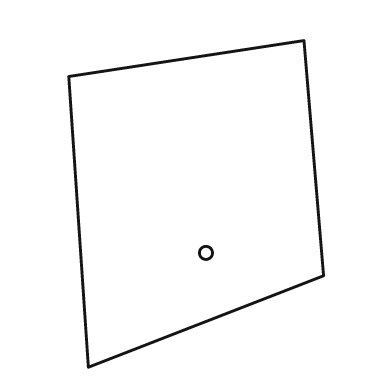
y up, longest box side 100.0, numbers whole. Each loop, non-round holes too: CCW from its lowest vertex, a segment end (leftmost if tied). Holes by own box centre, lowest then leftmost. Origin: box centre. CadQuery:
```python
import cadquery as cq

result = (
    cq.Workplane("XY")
    .moveTo(-33.0, -50.0)
    .lineTo(39.0, -22.0)
    .lineTo(33.0, 50.0)
    .lineTo(-39.0, 39.0)
    .close()
    .moveTo(3.0, -15.0)
    .circle(2.0)
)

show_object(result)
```